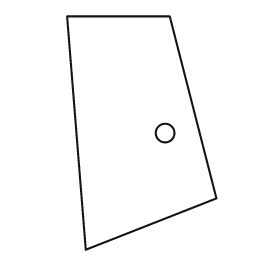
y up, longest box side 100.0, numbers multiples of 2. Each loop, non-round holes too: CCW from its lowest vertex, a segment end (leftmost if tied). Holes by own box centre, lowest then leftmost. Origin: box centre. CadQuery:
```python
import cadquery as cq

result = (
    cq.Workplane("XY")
    .moveTo(-24.0, -50.0)
    .lineTo(32.0, -28.0)
    .lineTo(12.0, 50.0)
    .lineTo(-32.0, 50.0)
    .close()
    .moveTo(10.0, 0.0)
    .circle(4.0)
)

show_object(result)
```